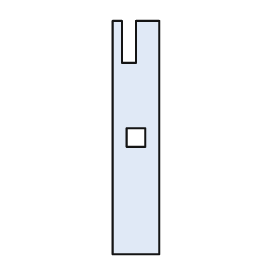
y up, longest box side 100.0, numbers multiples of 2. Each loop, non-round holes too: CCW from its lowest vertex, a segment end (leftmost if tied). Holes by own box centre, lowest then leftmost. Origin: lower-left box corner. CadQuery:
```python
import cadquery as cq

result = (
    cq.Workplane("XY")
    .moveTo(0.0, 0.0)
    .lineTo(20.0, 0.0)
    .lineTo(20.0, 100.0)
    .lineTo(10.0, 100.0)
    .lineTo(10.0, 82.0)
    .lineTo(4.0, 82.0)
    .lineTo(4.0, 100.0)
    .lineTo(0.0, 100.0)
    .close()
    .moveTo(6.0, 46.0)
    .lineTo(14.0, 46.0)
    .lineTo(14.0, 54.0)
    .lineTo(6.0, 54.0)
    .close()
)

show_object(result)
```